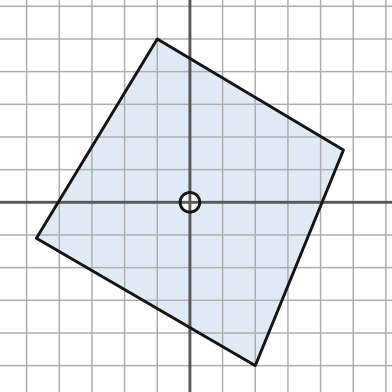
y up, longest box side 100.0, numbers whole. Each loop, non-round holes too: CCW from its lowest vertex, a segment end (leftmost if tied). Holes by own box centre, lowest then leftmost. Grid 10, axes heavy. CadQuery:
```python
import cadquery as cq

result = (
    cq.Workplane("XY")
    .moveTo(20.0, -50.0)
    .lineTo(47.0, 16.0)
    .lineTo(-10.0, 50.0)
    .lineTo(-47.0, -11.0)
    .close()
    .moveTo(0.0, 0.0)
    .circle(3.0)
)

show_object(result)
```